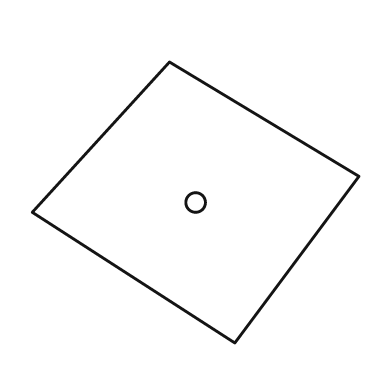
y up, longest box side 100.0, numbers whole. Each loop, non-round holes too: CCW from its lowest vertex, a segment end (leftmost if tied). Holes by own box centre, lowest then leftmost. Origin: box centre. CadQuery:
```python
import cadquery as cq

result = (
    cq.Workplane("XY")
    .moveTo(12.0, -43.0)
    .lineTo(50.0, 8.0)
    .lineTo(-8.0, 43.0)
    .lineTo(-50.0, -3.0)
    .close()
    .moveTo(0.0, 0.0)
    .circle(3.0)
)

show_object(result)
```